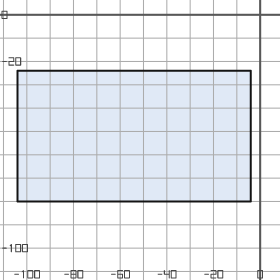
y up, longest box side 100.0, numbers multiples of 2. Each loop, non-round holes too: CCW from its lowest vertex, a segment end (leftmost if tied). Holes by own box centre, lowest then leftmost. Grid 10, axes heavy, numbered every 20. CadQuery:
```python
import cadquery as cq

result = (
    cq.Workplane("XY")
    .moveTo(-104.0, -80.0)
    .lineTo(-4.0, -80.0)
    .lineTo(-4.0, -24.0)
    .lineTo(-104.0, -24.0)
    .close()
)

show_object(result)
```